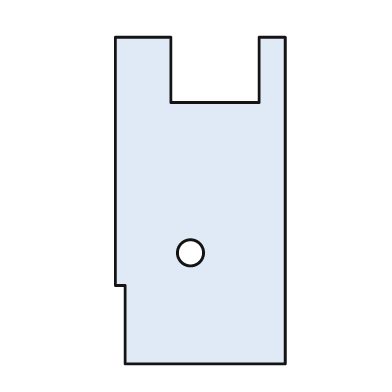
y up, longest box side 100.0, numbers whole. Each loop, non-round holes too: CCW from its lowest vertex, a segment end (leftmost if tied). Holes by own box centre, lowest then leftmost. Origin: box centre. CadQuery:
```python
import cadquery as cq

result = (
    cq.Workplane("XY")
    .moveTo(-23.0, -50.0)
    .lineTo(26.0, -50.0)
    .lineTo(26.0, 50.0)
    .lineTo(18.0, 50.0)
    .lineTo(18.0, 30.0)
    .lineTo(-9.0, 30.0)
    .lineTo(-9.0, 50.0)
    .lineTo(-26.0, 50.0)
    .lineTo(-26.0, -26.0)
    .lineTo(-23.0, -26.0)
    .close()
    .moveTo(-3.0, -16.0)
    .circle(4.0)
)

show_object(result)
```